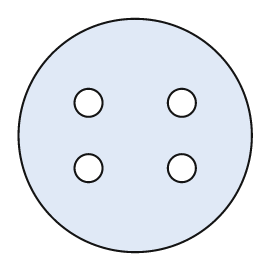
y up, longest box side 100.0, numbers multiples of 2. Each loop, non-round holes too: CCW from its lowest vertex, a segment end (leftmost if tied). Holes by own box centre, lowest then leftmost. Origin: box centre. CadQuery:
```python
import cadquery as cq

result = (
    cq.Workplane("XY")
    .moveTo(0.0, 0.0)
    .circle(50.0)
    .moveTo(-20.0, -14.0)
    .circle(6.0)
    .moveTo(20.0, -14.0)
    .circle(6.0)
    .moveTo(-20.0, 14.0)
    .circle(6.0)
    .moveTo(20.0, 14.0)
    .circle(6.0)
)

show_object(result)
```